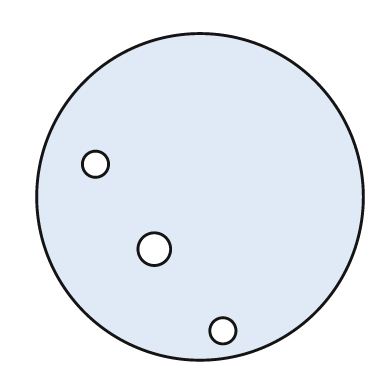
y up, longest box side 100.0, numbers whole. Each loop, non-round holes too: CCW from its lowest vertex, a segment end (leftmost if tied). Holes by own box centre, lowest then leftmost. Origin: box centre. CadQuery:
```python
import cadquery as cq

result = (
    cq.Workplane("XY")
    .moveTo(0.0, 0.0)
    .circle(50.0)
    .moveTo(7.0, -41.0)
    .circle(4.0)
    .moveTo(-14.0, -16.0)
    .circle(5.0)
    .moveTo(-32.0, 10.0)
    .circle(4.0)
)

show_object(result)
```